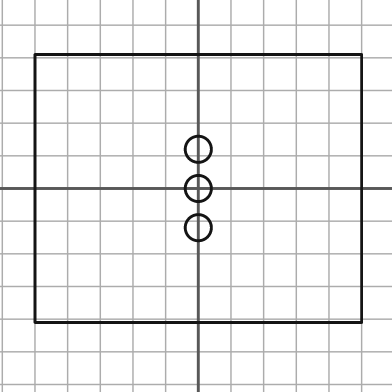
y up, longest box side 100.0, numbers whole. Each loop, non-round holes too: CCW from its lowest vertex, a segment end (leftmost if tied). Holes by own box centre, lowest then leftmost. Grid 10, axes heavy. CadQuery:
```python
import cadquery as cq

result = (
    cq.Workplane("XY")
    .moveTo(-50.0, -41.0)
    .lineTo(50.0, -41.0)
    .lineTo(50.0, 41.0)
    .lineTo(-50.0, 41.0)
    .close()
    .moveTo(0.0, -12.0)
    .circle(4.0)
    .moveTo(0.0, 0.0)
    .circle(4.0)
    .moveTo(0.0, 12.0)
    .circle(4.0)
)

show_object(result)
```